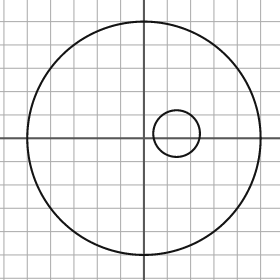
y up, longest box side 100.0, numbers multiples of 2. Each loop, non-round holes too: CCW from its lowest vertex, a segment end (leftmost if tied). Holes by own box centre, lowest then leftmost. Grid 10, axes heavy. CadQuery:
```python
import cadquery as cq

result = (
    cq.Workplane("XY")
    .moveTo(0.0, 0.0)
    .circle(50.0)
    .moveTo(14.0, 2.0)
    .circle(10.0)
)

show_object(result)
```